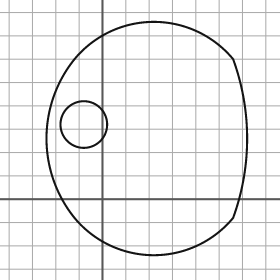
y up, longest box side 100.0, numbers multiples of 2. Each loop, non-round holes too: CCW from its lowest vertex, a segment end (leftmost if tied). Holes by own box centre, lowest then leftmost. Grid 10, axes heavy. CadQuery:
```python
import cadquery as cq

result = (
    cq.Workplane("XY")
    .moveTo(-12.0, -8.0)
    .threePointArc((22.0, -24.0), (56.0, -8.0))
    .threePointArc((62.0, 26.0), (56.0, 60.0))
    .threePointArc((22.0, 76.0), (-12.0, 60.0))
    .threePointArc((-24.0, 26.0), (-12.0, -8.0))
    .close()
    .moveTo(-8.0, 32.0)
    .circle(10.0)
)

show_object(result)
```